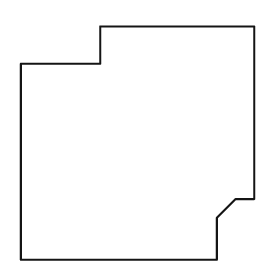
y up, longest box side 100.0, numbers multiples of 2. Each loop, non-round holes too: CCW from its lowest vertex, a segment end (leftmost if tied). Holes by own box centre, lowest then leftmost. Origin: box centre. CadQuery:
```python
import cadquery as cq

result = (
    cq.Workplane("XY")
    .moveTo(-50.0, -50.0)
    .lineTo(34.0, -50.0)
    .lineTo(34.0, -32.0)
    .lineTo(42.0, -24.0)
    .lineTo(50.0, -24.0)
    .lineTo(50.0, 50.0)
    .lineTo(-16.0, 50.0)
    .lineTo(-16.0, 34.0)
    .lineTo(-50.0, 34.0)
    .close()
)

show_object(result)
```